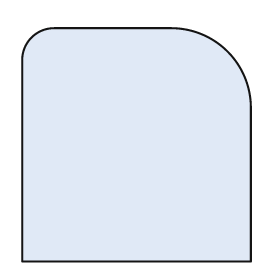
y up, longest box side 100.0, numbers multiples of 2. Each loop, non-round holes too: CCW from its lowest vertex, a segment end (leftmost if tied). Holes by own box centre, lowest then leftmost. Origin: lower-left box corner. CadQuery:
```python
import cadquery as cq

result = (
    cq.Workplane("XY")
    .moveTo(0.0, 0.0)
    .lineTo(98.0, 0.0)
    .lineTo(98.0, 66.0)
    .threePointArc((88.0, 90.0), (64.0, 100.0))
    .lineTo(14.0, 100.0)
    .threePointArc((4.0, 96.0), (0.0, 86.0))
    .close()
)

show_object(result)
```